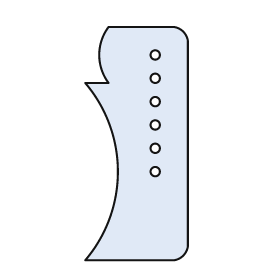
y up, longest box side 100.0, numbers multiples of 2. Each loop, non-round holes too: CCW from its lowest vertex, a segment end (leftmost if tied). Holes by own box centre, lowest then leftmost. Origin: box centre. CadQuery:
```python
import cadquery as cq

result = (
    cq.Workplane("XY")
    .moveTo(-22.0, -50.0)
    .lineTo(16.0, -50.0)
    .threePointArc((20.0, -48.0), (22.0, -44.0))
    .lineTo(22.0, 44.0)
    .threePointArc((20.0, 48.0), (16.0, 50.0))
    .lineTo(-12.0, 50.0)
    .threePointArc((-16.0, 38.0), (-12.0, 26.0))
    .lineTo(-22.0, 26.0)
    .threePointArc((-8.0, -12.0), (-22.0, -50.0))
    .close()
    .moveTo(8.0, -12.0)
    .circle(2.0)
    .moveTo(8.0, -2.0)
    .circle(2.0)
    .moveTo(8.0, 8.0)
    .circle(2.0)
    .moveTo(8.0, 18.0)
    .circle(2.0)
    .moveTo(8.0, 28.0)
    .circle(2.0)
    .moveTo(8.0, 38.0)
    .circle(2.0)
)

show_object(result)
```